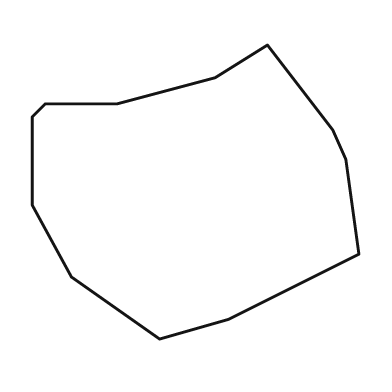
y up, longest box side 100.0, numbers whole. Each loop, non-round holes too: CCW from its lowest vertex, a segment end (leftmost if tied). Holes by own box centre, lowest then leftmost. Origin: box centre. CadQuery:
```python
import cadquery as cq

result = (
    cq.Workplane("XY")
    .moveTo(-11.0, -45.0)
    .lineTo(10.0, -39.0)
    .lineTo(50.0, -19.0)
    .lineTo(46.0, 10.0)
    .lineTo(42.0, 19.0)
    .lineTo(22.0, 45.0)
    .lineTo(6.0, 35.0)
    .lineTo(-24.0, 27.0)
    .lineTo(-46.0, 27.0)
    .lineTo(-50.0, 23.0)
    .lineTo(-50.0, -4.0)
    .lineTo(-38.0, -26.0)
    .close()
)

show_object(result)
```